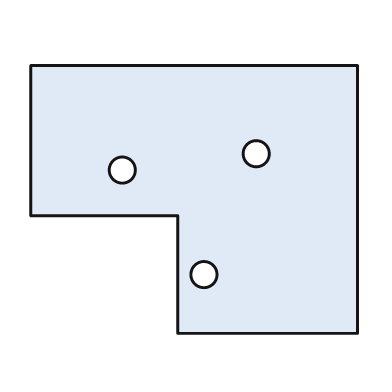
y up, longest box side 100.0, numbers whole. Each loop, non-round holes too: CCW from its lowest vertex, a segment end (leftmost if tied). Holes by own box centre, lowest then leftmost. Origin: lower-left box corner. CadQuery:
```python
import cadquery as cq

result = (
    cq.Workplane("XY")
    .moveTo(45.0, 0.0)
    .lineTo(100.0, 0.0)
    .lineTo(100.0, 82.0)
    .lineTo(0.0, 82.0)
    .lineTo(0.0, 36.0)
    .lineTo(45.0, 36.0)
    .close()
    .moveTo(53.0, 18.0)
    .circle(4.0)
    .moveTo(28.0, 50.0)
    .circle(4.0)
    .moveTo(69.0, 55.0)
    .circle(4.0)
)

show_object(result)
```